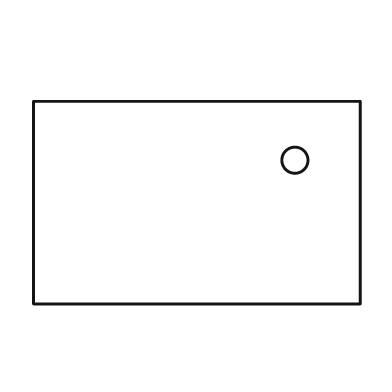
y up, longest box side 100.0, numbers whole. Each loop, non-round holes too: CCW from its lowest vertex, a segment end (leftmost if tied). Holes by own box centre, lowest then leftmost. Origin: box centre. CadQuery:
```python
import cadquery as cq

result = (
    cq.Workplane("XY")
    .moveTo(-50.0, -31.0)
    .lineTo(50.0, -31.0)
    .lineTo(50.0, 31.0)
    .lineTo(-50.0, 31.0)
    .close()
    .moveTo(30.0, 13.0)
    .circle(4.0)
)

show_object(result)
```